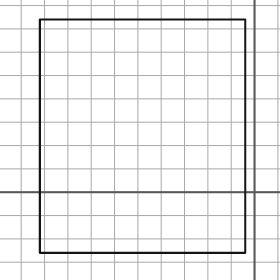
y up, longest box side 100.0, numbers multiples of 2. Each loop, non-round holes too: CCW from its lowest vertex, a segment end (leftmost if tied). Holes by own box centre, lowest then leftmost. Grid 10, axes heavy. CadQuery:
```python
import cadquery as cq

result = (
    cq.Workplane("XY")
    .moveTo(-92.0, -26.0)
    .lineTo(-4.0, -26.0)
    .lineTo(-4.0, 74.0)
    .lineTo(-92.0, 74.0)
    .close()
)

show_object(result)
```